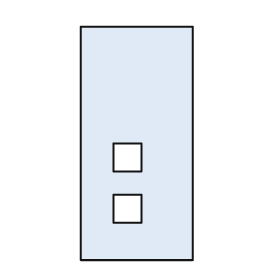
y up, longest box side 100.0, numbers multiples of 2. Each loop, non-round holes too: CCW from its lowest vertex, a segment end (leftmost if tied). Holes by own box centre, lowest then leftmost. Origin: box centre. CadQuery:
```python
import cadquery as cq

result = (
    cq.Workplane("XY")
    .moveTo(-24.0, -50.0)
    .lineTo(24.0, -50.0)
    .lineTo(24.0, 50.0)
    .lineTo(-24.0, 50.0)
    .close()
    .moveTo(-10.0, -34.0)
    .lineTo(2.0, -34.0)
    .lineTo(2.0, -22.0)
    .lineTo(-10.0, -22.0)
    .close()
    .moveTo(-10.0, -12.0)
    .lineTo(2.0, -12.0)
    .lineTo(2.0, 0.0)
    .lineTo(-10.0, 0.0)
    .close()
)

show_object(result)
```